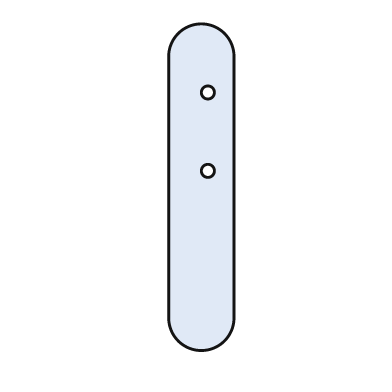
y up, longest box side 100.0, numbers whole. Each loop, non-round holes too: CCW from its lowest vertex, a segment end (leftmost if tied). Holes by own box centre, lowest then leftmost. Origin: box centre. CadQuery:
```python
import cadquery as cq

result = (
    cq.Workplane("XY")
    .moveTo(-10.0, -40.0)
    .threePointArc((0.0, -50.0), (10.0, -40.0))
    .lineTo(10.0, 40.0)
    .threePointArc((0.0, 50.0), (-10.0, 40.0))
    .close()
    .moveTo(2.0, 5.0)
    .circle(2.0)
    .moveTo(2.0, 29.0)
    .circle(2.0)
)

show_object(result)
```